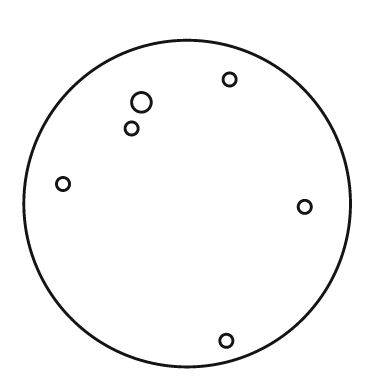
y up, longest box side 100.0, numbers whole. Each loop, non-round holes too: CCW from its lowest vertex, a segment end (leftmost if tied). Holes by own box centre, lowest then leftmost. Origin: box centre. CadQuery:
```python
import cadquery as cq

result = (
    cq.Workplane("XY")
    .moveTo(0.0, 0.0)
    .circle(50.0)
    .moveTo(12.0, -42.0)
    .circle(2.0)
    .moveTo(36.0, -1.0)
    .circle(2.0)
    .moveTo(-38.0, 6.0)
    .circle(2.0)
    .moveTo(-17.0, 23.0)
    .circle(2.0)
    .moveTo(-14.0, 31.0)
    .circle(3.0)
    .moveTo(13.0, 38.0)
    .circle(2.0)
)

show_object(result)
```